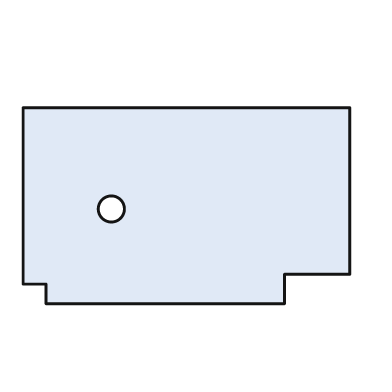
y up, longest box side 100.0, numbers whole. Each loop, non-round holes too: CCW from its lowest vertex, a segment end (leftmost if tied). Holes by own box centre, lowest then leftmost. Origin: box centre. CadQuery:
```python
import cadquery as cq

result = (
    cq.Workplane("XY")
    .moveTo(-43.0, -30.0)
    .lineTo(30.0, -30.0)
    .lineTo(30.0, -21.0)
    .lineTo(50.0, -21.0)
    .lineTo(50.0, 30.0)
    .lineTo(-50.0, 30.0)
    .lineTo(-50.0, -24.0)
    .lineTo(-43.0, -24.0)
    .close()
    .moveTo(-23.0, -1.0)
    .circle(4.0)
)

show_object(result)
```